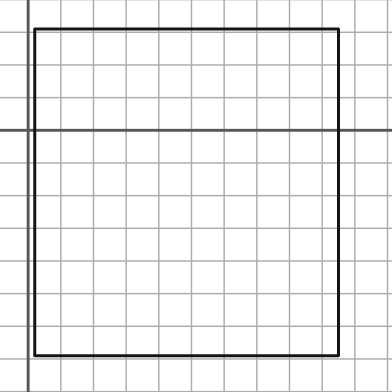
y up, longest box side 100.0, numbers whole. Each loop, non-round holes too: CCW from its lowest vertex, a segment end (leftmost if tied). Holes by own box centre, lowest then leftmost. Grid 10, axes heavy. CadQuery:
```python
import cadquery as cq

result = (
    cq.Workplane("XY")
    .moveTo(2.0, -69.0)
    .lineTo(95.0, -69.0)
    .lineTo(95.0, 31.0)
    .lineTo(2.0, 31.0)
    .close()
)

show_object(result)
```